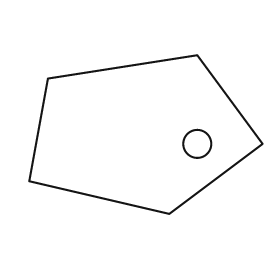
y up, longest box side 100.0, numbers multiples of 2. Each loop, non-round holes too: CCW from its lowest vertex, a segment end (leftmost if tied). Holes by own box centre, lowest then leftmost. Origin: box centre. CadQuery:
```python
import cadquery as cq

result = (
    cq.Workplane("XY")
    .moveTo(10.0, -34.0)
    .lineTo(50.0, -4.0)
    .lineTo(22.0, 34.0)
    .lineTo(-42.0, 24.0)
    .lineTo(-50.0, -20.0)
    .close()
    .moveTo(22.0, -4.0)
    .circle(6.0)
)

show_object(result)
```